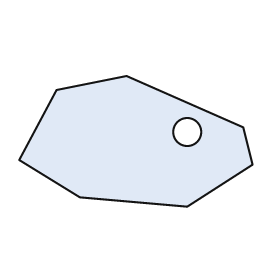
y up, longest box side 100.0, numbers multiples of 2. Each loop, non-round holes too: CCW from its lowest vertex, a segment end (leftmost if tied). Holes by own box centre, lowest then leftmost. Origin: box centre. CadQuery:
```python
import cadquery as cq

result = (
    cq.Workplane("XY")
    .moveTo(22.0, -28.0)
    .lineTo(50.0, -10.0)
    .lineTo(46.0, 6.0)
    .lineTo(-4.0, 28.0)
    .lineTo(-34.0, 22.0)
    .lineTo(-50.0, -8.0)
    .lineTo(-24.0, -24.0)
    .close()
    .moveTo(22.0, 4.0)
    .circle(6.0)
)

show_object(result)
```